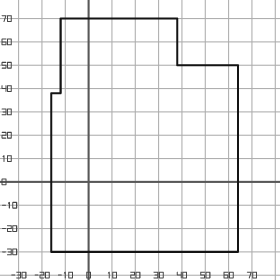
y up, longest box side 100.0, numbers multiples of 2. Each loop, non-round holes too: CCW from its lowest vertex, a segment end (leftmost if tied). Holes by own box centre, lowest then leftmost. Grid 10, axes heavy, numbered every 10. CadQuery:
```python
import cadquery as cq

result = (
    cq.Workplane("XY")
    .moveTo(-16.0, -30.0)
    .lineTo(64.0, -30.0)
    .lineTo(64.0, 50.0)
    .lineTo(38.0, 50.0)
    .lineTo(38.0, 70.0)
    .lineTo(-12.0, 70.0)
    .lineTo(-12.0, 38.0)
    .lineTo(-16.0, 38.0)
    .close()
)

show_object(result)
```